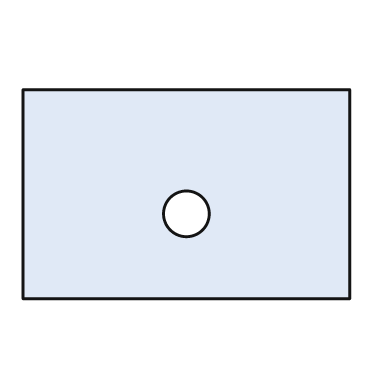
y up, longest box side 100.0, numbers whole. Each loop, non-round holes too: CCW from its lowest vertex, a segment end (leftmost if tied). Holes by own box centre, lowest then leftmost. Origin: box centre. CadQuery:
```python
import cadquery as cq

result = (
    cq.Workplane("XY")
    .moveTo(-50.0, -32.0)
    .lineTo(50.0, -32.0)
    .lineTo(50.0, 32.0)
    .lineTo(-50.0, 32.0)
    .close()
    .moveTo(0.0, -6.0)
    .circle(7.0)
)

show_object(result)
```